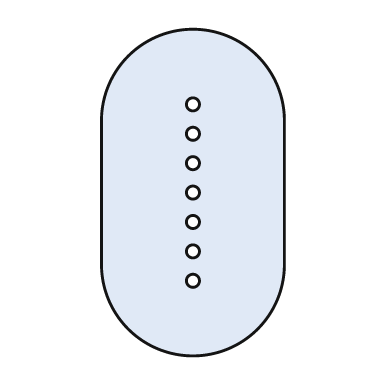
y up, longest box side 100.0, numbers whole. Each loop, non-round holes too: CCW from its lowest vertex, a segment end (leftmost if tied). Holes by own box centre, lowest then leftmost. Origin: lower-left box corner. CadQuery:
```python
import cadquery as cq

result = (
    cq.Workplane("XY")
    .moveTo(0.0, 28.0)
    .threePointArc((28.0, 0.0), (56.0, 28.0))
    .lineTo(56.0, 72.0)
    .threePointArc((28.0, 100.0), (0.0, 72.0))
    .close()
    .moveTo(28.0, 23.0)
    .circle(2.0)
    .moveTo(28.0, 32.0)
    .circle(2.0)
    .moveTo(28.0, 41.0)
    .circle(2.0)
    .moveTo(28.0, 50.0)
    .circle(2.0)
    .moveTo(28.0, 59.0)
    .circle(2.0)
    .moveTo(28.0, 68.0)
    .circle(2.0)
    .moveTo(28.0, 77.0)
    .circle(2.0)
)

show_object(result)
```